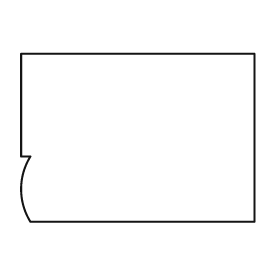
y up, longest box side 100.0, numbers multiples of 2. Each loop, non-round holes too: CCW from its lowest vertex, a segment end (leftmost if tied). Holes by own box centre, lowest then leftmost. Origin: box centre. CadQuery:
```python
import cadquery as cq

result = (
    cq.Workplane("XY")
    .moveTo(-46.0, -36.0)
    .lineTo(50.0, -36.0)
    .lineTo(50.0, 36.0)
    .lineTo(-50.0, 36.0)
    .lineTo(-50.0, -8.0)
    .lineTo(-46.0, -8.0)
    .threePointArc((-50.0, -22.0), (-46.0, -36.0))
    .close()
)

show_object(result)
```